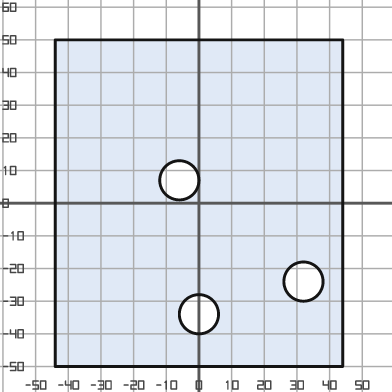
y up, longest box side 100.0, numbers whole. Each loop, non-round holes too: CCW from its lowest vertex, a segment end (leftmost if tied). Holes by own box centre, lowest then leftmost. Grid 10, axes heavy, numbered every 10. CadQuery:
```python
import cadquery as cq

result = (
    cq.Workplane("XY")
    .moveTo(-44.0, -50.0)
    .lineTo(44.0, -50.0)
    .lineTo(44.0, 50.0)
    .lineTo(-44.0, 50.0)
    .close()
    .moveTo(0.0, -34.0)
    .circle(6.0)
    .moveTo(32.0, -24.0)
    .circle(6.0)
    .moveTo(-6.0, 7.0)
    .circle(6.0)
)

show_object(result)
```